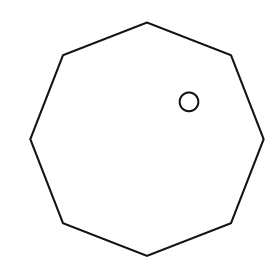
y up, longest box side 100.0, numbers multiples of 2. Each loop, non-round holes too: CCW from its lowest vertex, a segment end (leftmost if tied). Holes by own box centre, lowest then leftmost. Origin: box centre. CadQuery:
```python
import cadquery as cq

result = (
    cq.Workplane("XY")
    .moveTo(0.0, -50.0)
    .lineTo(36.0, -36.0)
    .lineTo(50.0, 0.0)
    .lineTo(36.0, 36.0)
    .lineTo(0.0, 50.0)
    .lineTo(-36.0, 36.0)
    .lineTo(-50.0, 0.0)
    .lineTo(-36.0, -36.0)
    .close()
    .moveTo(18.0, 16.0)
    .circle(4.0)
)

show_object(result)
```